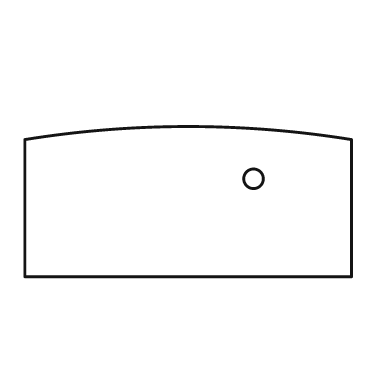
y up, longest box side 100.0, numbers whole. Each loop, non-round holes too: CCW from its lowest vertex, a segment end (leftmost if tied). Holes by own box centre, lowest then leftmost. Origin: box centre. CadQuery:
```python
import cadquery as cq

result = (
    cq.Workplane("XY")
    .moveTo(-50.0, -23.0)
    .lineTo(50.0, -23.0)
    .lineTo(50.0, 19.0)
    .threePointArc((0.0, 23.0), (-50.0, 19.0))
    .close()
    .moveTo(20.0, 7.0)
    .circle(3.0)
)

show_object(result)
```